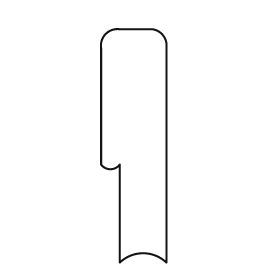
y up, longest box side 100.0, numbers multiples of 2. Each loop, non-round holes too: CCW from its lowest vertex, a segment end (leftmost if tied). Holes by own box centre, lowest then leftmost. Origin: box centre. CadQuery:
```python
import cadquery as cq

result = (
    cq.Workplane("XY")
    .moveTo(-6.0, -50.0)
    .threePointArc((4.0, -46.0), (14.0, -50.0))
    .lineTo(14.0, 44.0)
    .threePointArc((12.0, 48.0), (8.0, 50.0))
    .lineTo(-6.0, 50.0)
    .threePointArc((-12.0, 48.0), (-14.0, 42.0))
    .lineTo(-14.0, -8.0)
    .threePointArc((-10.0, -10.0), (-6.0, -8.0))
    .close()
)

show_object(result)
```